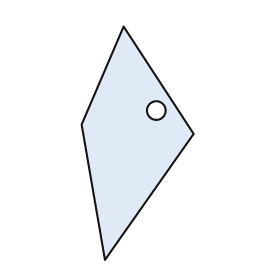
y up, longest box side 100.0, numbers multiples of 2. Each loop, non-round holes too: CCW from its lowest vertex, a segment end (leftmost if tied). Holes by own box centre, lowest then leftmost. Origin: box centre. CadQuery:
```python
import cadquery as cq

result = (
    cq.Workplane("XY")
    .moveTo(-14.0, -50.0)
    .lineTo(24.0, 4.0)
    .lineTo(-6.0, 50.0)
    .lineTo(-24.0, 8.0)
    .close()
    .moveTo(8.0, 14.0)
    .circle(4.0)
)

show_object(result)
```